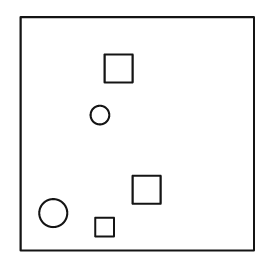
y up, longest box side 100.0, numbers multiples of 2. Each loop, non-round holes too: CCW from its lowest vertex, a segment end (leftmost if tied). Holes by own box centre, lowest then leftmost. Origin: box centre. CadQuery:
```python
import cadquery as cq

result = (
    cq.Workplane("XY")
    .moveTo(-50.0, -50.0)
    .lineTo(50.0, -50.0)
    .lineTo(50.0, 50.0)
    .lineTo(-50.0, 50.0)
    .close()
    .moveTo(-18.0, -44.0)
    .lineTo(-10.0, -44.0)
    .lineTo(-10.0, -36.0)
    .lineTo(-18.0, -36.0)
    .close()
    .moveTo(-36.0, -34.0)
    .circle(6.0)
    .moveTo(-2.0, -30.0)
    .lineTo(10.0, -30.0)
    .lineTo(10.0, -18.0)
    .lineTo(-2.0, -18.0)
    .close()
    .moveTo(-16.0, 8.0)
    .circle(4.0)
    .moveTo(-14.0, 22.0)
    .lineTo(-2.0, 22.0)
    .lineTo(-2.0, 34.0)
    .lineTo(-14.0, 34.0)
    .close()
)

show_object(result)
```